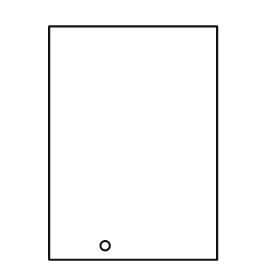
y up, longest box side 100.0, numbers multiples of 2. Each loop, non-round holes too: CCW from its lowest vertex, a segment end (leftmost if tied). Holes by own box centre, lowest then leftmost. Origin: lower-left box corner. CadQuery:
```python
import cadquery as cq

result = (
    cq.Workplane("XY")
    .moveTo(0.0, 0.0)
    .lineTo(72.0, 0.0)
    .lineTo(72.0, 100.0)
    .lineTo(0.0, 100.0)
    .close()
    .moveTo(24.0, 6.0)
    .circle(2.0)
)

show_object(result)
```